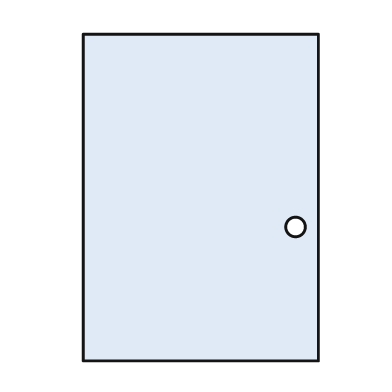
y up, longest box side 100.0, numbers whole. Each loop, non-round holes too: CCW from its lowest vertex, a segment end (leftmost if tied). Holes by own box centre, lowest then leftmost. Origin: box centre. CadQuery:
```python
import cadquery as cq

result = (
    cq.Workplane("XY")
    .moveTo(-36.0, -50.0)
    .lineTo(36.0, -50.0)
    .lineTo(36.0, 50.0)
    .lineTo(-36.0, 50.0)
    .close()
    .moveTo(29.0, -9.0)
    .circle(3.0)
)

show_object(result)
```